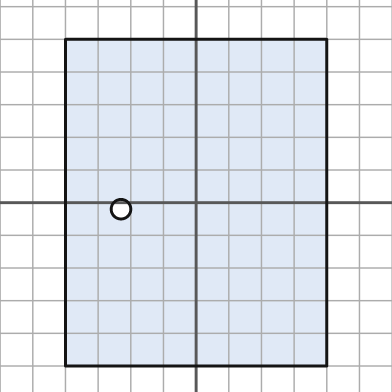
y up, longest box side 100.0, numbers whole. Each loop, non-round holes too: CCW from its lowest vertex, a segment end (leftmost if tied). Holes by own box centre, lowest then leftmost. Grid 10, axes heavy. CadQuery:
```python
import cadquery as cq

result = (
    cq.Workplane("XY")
    .moveTo(-40.0, -50.0)
    .lineTo(40.0, -50.0)
    .lineTo(40.0, 50.0)
    .lineTo(-40.0, 50.0)
    .close()
    .moveTo(-23.0, -2.0)
    .circle(3.0)
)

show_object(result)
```